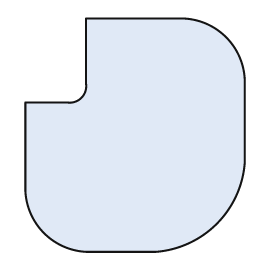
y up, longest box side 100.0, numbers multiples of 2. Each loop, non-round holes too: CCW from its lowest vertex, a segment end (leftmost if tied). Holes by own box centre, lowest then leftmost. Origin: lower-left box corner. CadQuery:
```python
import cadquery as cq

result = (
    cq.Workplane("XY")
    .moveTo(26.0, 0.0)
    .lineTo(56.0, 0.0)
    .threePointArc((82.0, 12.0), (94.0, 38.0))
    .lineTo(94.0, 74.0)
    .threePointArc((86.0, 92.0), (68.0, 100.0))
    .lineTo(26.0, 100.0)
    .lineTo(26.0, 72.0)
    .threePointArc((24.0, 66.0), (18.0, 64.0))
    .lineTo(0.0, 64.0)
    .lineTo(0.0, 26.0)
    .threePointArc((8.0, 8.0), (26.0, 0.0))
    .close()
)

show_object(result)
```